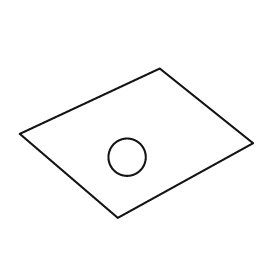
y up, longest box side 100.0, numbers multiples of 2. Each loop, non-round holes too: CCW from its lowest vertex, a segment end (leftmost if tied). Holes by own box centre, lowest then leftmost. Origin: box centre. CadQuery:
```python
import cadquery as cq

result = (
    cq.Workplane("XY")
    .moveTo(-8.0, -32.0)
    .lineTo(50.0, 0.0)
    .lineTo(10.0, 32.0)
    .lineTo(-50.0, 4.0)
    .close()
    .moveTo(-4.0, -6.0)
    .circle(8.0)
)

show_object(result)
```